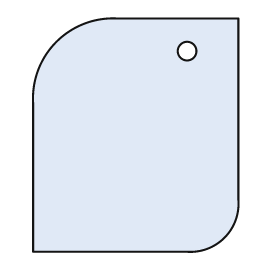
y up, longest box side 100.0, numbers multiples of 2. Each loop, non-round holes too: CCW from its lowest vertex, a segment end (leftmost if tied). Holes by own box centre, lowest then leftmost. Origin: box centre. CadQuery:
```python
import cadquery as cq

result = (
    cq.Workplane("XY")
    .moveTo(-44.0, -50.0)
    .lineTo(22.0, -50.0)
    .threePointArc((38.0, -44.0), (44.0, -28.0))
    .lineTo(44.0, 50.0)
    .lineTo(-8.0, 50.0)
    .threePointArc((-34.0, 40.0), (-44.0, 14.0))
    .close()
    .moveTo(22.0, 36.0)
    .circle(4.0)
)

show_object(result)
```